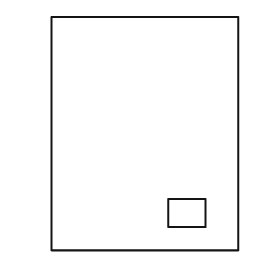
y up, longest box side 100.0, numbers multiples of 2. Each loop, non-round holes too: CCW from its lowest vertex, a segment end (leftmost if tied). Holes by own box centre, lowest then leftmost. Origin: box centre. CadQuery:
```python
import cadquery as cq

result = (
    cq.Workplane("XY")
    .moveTo(-40.0, -50.0)
    .lineTo(40.0, -50.0)
    .lineTo(40.0, 50.0)
    .lineTo(-40.0, 50.0)
    .close()
    .moveTo(10.0, -40.0)
    .lineTo(26.0, -40.0)
    .lineTo(26.0, -28.0)
    .lineTo(10.0, -28.0)
    .close()
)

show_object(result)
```